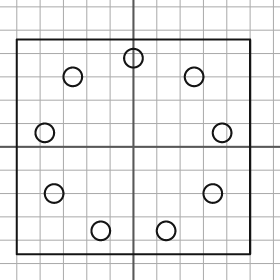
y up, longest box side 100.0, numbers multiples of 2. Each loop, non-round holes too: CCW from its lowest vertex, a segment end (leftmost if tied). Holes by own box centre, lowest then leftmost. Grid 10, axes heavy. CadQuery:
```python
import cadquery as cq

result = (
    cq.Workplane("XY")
    .moveTo(-50.0, -46.0)
    .lineTo(50.0, -46.0)
    .lineTo(50.0, 46.0)
    .lineTo(-50.0, 46.0)
    .close()
    .moveTo(-14.0, -36.0)
    .circle(4.0)
    .moveTo(14.0, -36.0)
    .circle(4.0)
    .moveTo(-34.0, -20.0)
    .circle(4.0)
    .moveTo(34.0, -20.0)
    .circle(4.0)
    .moveTo(-38.0, 6.0)
    .circle(4.0)
    .moveTo(38.0, 6.0)
    .circle(4.0)
    .moveTo(-26.0, 30.0)
    .circle(4.0)
    .moveTo(26.0, 30.0)
    .circle(4.0)
    .moveTo(0.0, 38.0)
    .circle(4.0)
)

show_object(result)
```